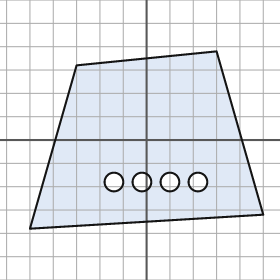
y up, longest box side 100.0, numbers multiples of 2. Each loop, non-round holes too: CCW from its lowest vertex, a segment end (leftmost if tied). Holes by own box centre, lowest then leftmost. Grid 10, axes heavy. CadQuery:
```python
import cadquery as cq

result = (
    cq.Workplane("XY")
    .moveTo(-50.0, -38.0)
    .lineTo(50.0, -32.0)
    .lineTo(30.0, 38.0)
    .lineTo(-30.0, 32.0)
    .close()
    .moveTo(-14.0, -18.0)
    .circle(4.0)
    .moveTo(-2.0, -18.0)
    .circle(4.0)
    .moveTo(10.0, -18.0)
    .circle(4.0)
    .moveTo(22.0, -18.0)
    .circle(4.0)
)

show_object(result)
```